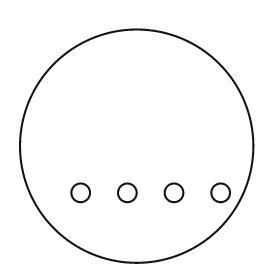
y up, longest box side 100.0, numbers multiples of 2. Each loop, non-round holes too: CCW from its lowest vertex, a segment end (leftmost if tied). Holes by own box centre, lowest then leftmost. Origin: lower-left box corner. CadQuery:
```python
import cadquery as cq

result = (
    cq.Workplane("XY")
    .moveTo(50.0, 50.0)
    .circle(50.0)
    .moveTo(26.0, 30.0)
    .circle(4.0)
    .moveTo(46.0, 30.0)
    .circle(4.0)
    .moveTo(66.0, 30.0)
    .circle(4.0)
    .moveTo(86.0, 30.0)
    .circle(4.0)
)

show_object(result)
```